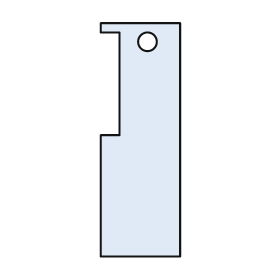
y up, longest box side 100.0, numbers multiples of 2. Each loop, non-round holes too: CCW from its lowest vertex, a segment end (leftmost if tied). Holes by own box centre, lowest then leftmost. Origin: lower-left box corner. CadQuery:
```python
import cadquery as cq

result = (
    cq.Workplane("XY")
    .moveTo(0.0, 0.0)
    .lineTo(34.0, 0.0)
    .lineTo(34.0, 100.0)
    .lineTo(0.0, 100.0)
    .lineTo(0.0, 96.0)
    .lineTo(8.0, 96.0)
    .lineTo(8.0, 52.0)
    .lineTo(0.0, 52.0)
    .close()
    .moveTo(20.0, 92.0)
    .circle(4.0)
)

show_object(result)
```